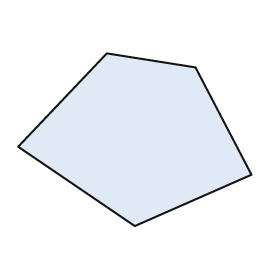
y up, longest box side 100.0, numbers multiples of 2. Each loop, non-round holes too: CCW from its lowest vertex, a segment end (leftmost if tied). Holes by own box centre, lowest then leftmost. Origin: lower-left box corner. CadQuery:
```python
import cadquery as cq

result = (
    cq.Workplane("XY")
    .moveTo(50.0, 0.0)
    .lineTo(100.0, 22.0)
    .lineTo(76.0, 68.0)
    .lineTo(38.0, 74.0)
    .lineTo(0.0, 34.0)
    .close()
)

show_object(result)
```